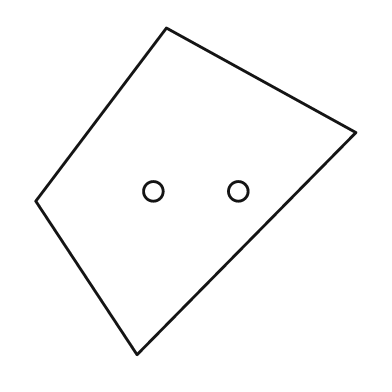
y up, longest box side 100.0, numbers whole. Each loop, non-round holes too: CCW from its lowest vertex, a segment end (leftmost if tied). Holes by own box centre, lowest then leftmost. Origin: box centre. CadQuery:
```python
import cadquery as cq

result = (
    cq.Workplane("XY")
    .moveTo(-18.0, -50.0)
    .lineTo(49.0, 18.0)
    .lineTo(-9.0, 50.0)
    .lineTo(-49.0, -3.0)
    .close()
    .moveTo(-13.0, 0.0)
    .circle(3.0)
    .moveTo(13.0, 0.0)
    .circle(3.0)
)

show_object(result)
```